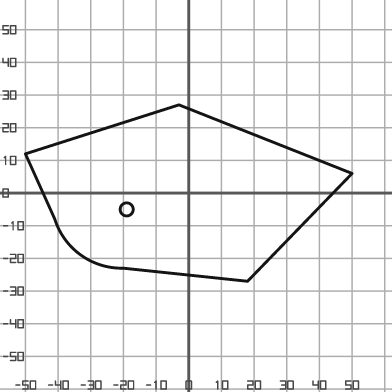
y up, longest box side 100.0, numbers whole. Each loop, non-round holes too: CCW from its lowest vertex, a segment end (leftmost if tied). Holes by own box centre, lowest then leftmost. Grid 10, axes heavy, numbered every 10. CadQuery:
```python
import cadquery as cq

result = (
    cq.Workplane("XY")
    .moveTo(18.0, -27.0)
    .lineTo(50.0, 6.0)
    .lineTo(-3.0, 27.0)
    .lineTo(-50.0, 12.0)
    .lineTo(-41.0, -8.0)
    .threePointArc((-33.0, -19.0), (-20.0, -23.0))
    .close()
    .moveTo(-19.0, -5.0)
    .circle(2.0)
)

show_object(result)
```